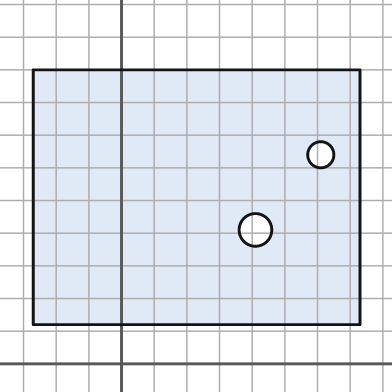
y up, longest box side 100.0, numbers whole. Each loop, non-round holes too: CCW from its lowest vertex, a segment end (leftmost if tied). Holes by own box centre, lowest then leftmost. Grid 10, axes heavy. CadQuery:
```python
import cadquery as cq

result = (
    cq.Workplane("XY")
    .moveTo(-27.0, 12.0)
    .lineTo(73.0, 12.0)
    .lineTo(73.0, 90.0)
    .lineTo(-27.0, 90.0)
    .close()
    .moveTo(41.0, 41.0)
    .circle(5.0)
    .moveTo(61.0, 64.0)
    .circle(4.0)
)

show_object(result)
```